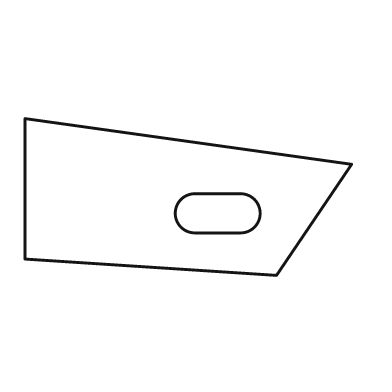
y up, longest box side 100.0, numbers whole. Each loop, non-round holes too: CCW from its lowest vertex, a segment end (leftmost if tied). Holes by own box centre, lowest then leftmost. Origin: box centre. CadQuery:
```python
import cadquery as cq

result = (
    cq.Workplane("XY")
    .moveTo(27.0, -24.0)
    .lineTo(50.0, 10.0)
    .lineTo(-50.0, 24.0)
    .lineTo(-50.0, -19.0)
    .close()
    .moveTo(2.0, -11.0)
    .lineTo(16.0, -11.0)
    .threePointArc((22.0, -5.0), (16.0, 1.0))
    .lineTo(2.0, 1.0)
    .threePointArc((-4.0, -5.0), (2.0, -11.0))
    .close()
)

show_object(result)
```